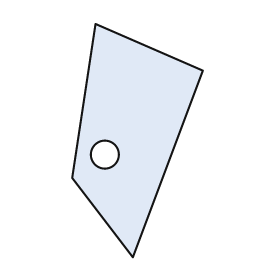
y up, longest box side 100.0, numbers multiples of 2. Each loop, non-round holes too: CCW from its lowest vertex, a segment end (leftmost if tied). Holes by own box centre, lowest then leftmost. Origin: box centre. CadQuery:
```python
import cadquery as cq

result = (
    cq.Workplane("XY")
    .moveTo(-2.0, -50.0)
    .lineTo(28.0, 30.0)
    .lineTo(-18.0, 50.0)
    .lineTo(-28.0, -16.0)
    .close()
    .moveTo(-14.0, -6.0)
    .circle(6.0)
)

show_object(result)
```